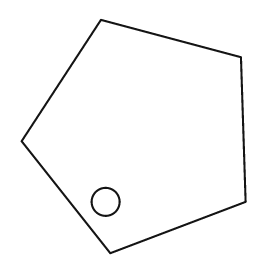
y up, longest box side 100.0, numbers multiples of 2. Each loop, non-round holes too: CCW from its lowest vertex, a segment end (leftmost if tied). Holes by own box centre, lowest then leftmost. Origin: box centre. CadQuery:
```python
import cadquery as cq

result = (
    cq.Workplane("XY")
    .moveTo(-10.0, -50.0)
    .lineTo(48.0, -28.0)
    .lineTo(46.0, 34.0)
    .lineTo(-14.0, 50.0)
    .lineTo(-48.0, -2.0)
    .close()
    .moveTo(-12.0, -28.0)
    .circle(6.0)
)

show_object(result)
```